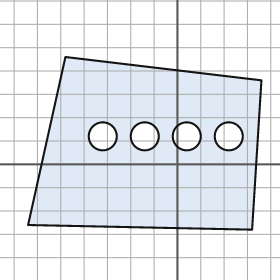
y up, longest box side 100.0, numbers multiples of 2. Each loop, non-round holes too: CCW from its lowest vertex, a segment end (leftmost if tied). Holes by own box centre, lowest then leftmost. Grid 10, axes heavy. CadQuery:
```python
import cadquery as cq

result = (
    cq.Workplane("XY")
    .moveTo(32.0, -28.0)
    .lineTo(36.0, 36.0)
    .lineTo(-48.0, 46.0)
    .lineTo(-64.0, -26.0)
    .close()
    .moveTo(-32.0, 12.0)
    .circle(6.0)
    .moveTo(-14.0, 12.0)
    .circle(6.0)
    .moveTo(4.0, 12.0)
    .circle(6.0)
    .moveTo(22.0, 12.0)
    .circle(6.0)
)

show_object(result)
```